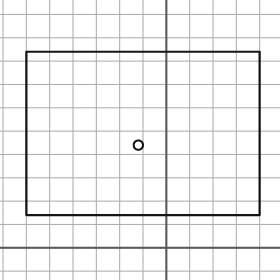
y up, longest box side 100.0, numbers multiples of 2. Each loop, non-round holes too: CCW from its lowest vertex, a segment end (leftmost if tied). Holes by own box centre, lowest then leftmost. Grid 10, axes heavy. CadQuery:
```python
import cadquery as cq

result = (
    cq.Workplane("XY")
    .moveTo(-60.0, 14.0)
    .lineTo(40.0, 14.0)
    .lineTo(40.0, 84.0)
    .lineTo(-60.0, 84.0)
    .close()
    .moveTo(-12.0, 44.0)
    .circle(2.0)
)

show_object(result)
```